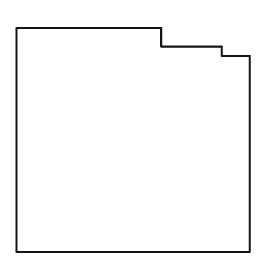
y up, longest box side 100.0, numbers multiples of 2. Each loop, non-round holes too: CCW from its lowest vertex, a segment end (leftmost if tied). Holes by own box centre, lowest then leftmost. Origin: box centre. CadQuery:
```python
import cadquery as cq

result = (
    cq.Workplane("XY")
    .moveTo(-50.0, -48.0)
    .lineTo(50.0, -48.0)
    .lineTo(50.0, 36.0)
    .lineTo(38.0, 36.0)
    .lineTo(38.0, 40.0)
    .lineTo(12.0, 40.0)
    .lineTo(12.0, 48.0)
    .lineTo(-50.0, 48.0)
    .close()
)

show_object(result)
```